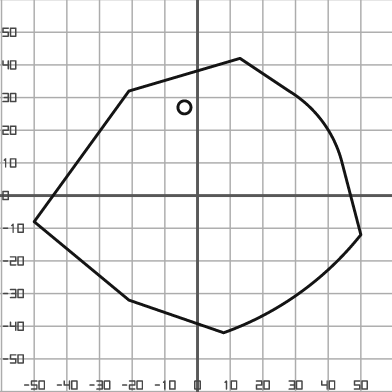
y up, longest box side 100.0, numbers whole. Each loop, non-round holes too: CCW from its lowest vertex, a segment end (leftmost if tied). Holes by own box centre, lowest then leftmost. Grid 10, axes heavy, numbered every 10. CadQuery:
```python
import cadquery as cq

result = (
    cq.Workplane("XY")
    .moveTo(8.0, -42.0)
    .threePointArc((31.0, -30.0), (50.0, -12.0))
    .lineTo(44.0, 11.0)
    .threePointArc((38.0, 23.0), (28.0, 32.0))
    .lineTo(13.0, 42.0)
    .lineTo(-21.0, 32.0)
    .lineTo(-50.0, -8.0)
    .lineTo(-21.0, -32.0)
    .close()
    .moveTo(-4.0, 27.0)
    .circle(2.0)
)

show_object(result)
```